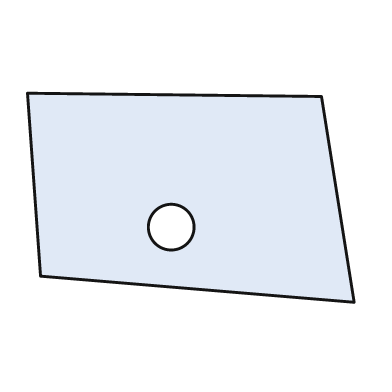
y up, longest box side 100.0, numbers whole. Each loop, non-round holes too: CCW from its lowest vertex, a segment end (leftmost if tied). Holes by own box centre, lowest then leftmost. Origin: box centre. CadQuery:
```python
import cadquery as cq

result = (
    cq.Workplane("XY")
    .moveTo(50.0, -32.0)
    .lineTo(40.0, 31.0)
    .lineTo(-50.0, 32.0)
    .lineTo(-46.0, -24.0)
    .close()
    .moveTo(-6.0, -9.0)
    .circle(7.0)
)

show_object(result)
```